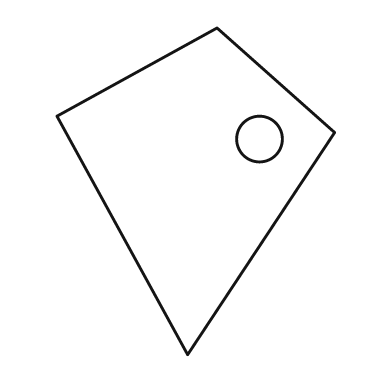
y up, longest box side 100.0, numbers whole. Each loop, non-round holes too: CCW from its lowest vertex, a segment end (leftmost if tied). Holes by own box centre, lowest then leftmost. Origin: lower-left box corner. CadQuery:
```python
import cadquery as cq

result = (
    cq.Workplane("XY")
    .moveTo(40.0, 0.0)
    .lineTo(85.0, 68.0)
    .lineTo(49.0, 100.0)
    .lineTo(0.0, 73.0)
    .close()
    .moveTo(62.0, 66.0)
    .circle(7.0)
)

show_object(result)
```